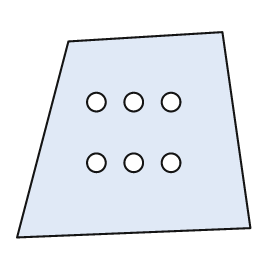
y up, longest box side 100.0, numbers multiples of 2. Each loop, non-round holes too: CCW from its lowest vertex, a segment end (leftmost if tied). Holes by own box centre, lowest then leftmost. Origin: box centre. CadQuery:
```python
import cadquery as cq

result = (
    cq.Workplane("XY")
    .moveTo(-50.0, -44.0)
    .lineTo(50.0, -40.0)
    .lineTo(38.0, 44.0)
    .lineTo(-28.0, 40.0)
    .close()
    .moveTo(-16.0, -12.0)
    .circle(4.0)
    .moveTo(0.0, -12.0)
    .circle(4.0)
    .moveTo(16.0, -12.0)
    .circle(4.0)
    .moveTo(-16.0, 14.0)
    .circle(4.0)
    .moveTo(0.0, 14.0)
    .circle(4.0)
    .moveTo(16.0, 14.0)
    .circle(4.0)
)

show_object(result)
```